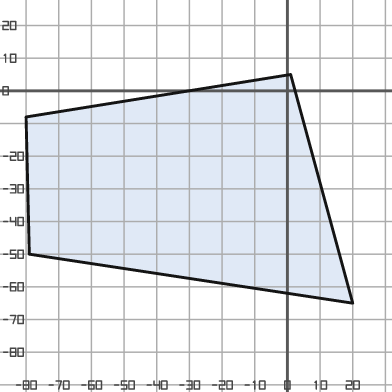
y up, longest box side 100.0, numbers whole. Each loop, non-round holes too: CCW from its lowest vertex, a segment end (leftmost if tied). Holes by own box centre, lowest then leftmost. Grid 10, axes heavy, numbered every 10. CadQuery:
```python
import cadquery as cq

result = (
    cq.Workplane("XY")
    .moveTo(20.0, -65.0)
    .lineTo(1.0, 5.0)
    .lineTo(-80.0, -8.0)
    .lineTo(-79.0, -50.0)
    .close()
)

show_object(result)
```